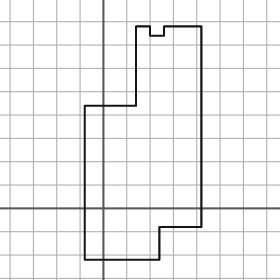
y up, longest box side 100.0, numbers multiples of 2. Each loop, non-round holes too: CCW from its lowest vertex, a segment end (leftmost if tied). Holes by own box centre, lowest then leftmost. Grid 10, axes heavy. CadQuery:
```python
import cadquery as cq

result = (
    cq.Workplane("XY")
    .moveTo(-8.0, -22.0)
    .lineTo(24.0, -22.0)
    .lineTo(24.0, -8.0)
    .lineTo(42.0, -8.0)
    .lineTo(42.0, 78.0)
    .lineTo(26.0, 78.0)
    .lineTo(26.0, 74.0)
    .lineTo(20.0, 74.0)
    .lineTo(20.0, 78.0)
    .lineTo(14.0, 78.0)
    .lineTo(14.0, 44.0)
    .lineTo(-8.0, 44.0)
    .close()
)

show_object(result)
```